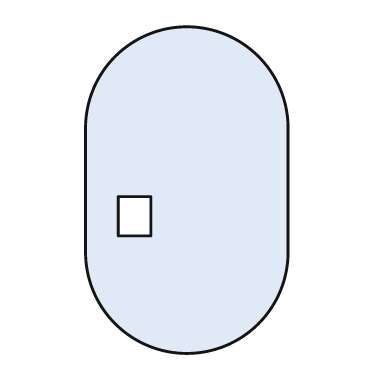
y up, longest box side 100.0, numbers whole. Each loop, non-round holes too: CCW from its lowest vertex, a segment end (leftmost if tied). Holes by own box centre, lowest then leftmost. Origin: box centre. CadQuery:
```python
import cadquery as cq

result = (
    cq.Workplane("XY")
    .moveTo(-31.0, -19.0)
    .threePointArc((0.0, -50.0), (31.0, -19.0))
    .lineTo(31.0, 19.0)
    .threePointArc((0.0, 50.0), (-31.0, 19.0))
    .close()
    .moveTo(-21.0, -14.0)
    .lineTo(-11.0, -14.0)
    .lineTo(-11.0, -2.0)
    .lineTo(-21.0, -2.0)
    .close()
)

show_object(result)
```